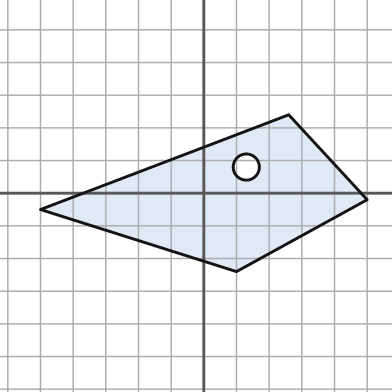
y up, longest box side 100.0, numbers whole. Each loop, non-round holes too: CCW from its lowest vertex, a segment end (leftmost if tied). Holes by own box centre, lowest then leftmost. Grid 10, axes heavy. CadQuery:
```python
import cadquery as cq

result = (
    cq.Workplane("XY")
    .moveTo(10.0, -24.0)
    .lineTo(50.0, -2.0)
    .lineTo(26.0, 24.0)
    .lineTo(-50.0, -5.0)
    .close()
    .moveTo(13.0, 8.0)
    .circle(4.0)
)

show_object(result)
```